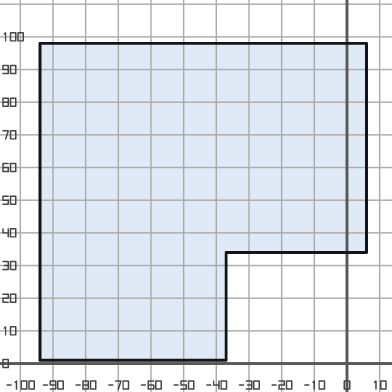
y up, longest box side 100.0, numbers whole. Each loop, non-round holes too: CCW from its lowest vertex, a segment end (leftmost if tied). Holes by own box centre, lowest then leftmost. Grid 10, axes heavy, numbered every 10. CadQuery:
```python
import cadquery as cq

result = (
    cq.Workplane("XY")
    .moveTo(-94.0, 1.0)
    .lineTo(-37.0, 1.0)
    .lineTo(-37.0, 34.0)
    .lineTo(6.0, 34.0)
    .lineTo(6.0, 98.0)
    .lineTo(-94.0, 98.0)
    .close()
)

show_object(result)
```